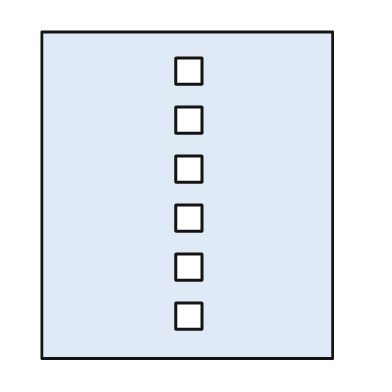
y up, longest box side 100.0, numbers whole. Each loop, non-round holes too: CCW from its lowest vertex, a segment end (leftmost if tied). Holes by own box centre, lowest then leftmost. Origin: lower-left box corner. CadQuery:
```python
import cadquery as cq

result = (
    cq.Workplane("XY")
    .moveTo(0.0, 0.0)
    .lineTo(89.0, 0.0)
    .lineTo(89.0, 100.0)
    .lineTo(0.0, 100.0)
    .close()
    .moveTo(41.0, 9.0)
    .lineTo(49.0, 9.0)
    .lineTo(49.0, 17.0)
    .lineTo(41.0, 17.0)
    .close()
    .moveTo(41.0, 24.0)
    .lineTo(49.0, 24.0)
    .lineTo(49.0, 32.0)
    .lineTo(41.0, 32.0)
    .close()
    .moveTo(41.0, 39.0)
    .lineTo(49.0, 39.0)
    .lineTo(49.0, 47.0)
    .lineTo(41.0, 47.0)
    .close()
    .moveTo(41.0, 54.0)
    .lineTo(49.0, 54.0)
    .lineTo(49.0, 62.0)
    .lineTo(41.0, 62.0)
    .close()
    .moveTo(41.0, 69.0)
    .lineTo(49.0, 69.0)
    .lineTo(49.0, 77.0)
    .lineTo(41.0, 77.0)
    .close()
    .moveTo(41.0, 84.0)
    .lineTo(49.0, 84.0)
    .lineTo(49.0, 92.0)
    .lineTo(41.0, 92.0)
    .close()
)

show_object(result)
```